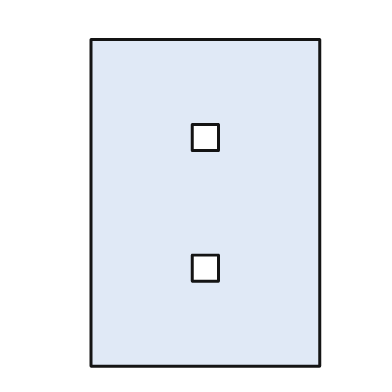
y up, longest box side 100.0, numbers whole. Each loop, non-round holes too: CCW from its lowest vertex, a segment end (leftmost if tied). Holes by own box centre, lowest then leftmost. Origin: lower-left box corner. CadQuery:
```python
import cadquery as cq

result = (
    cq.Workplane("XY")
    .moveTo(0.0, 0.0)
    .lineTo(70.0, 0.0)
    .lineTo(70.0, 100.0)
    .lineTo(0.0, 100.0)
    .close()
    .moveTo(31.0, 26.0)
    .lineTo(39.0, 26.0)
    .lineTo(39.0, 34.0)
    .lineTo(31.0, 34.0)
    .close()
    .moveTo(31.0, 66.0)
    .lineTo(39.0, 66.0)
    .lineTo(39.0, 74.0)
    .lineTo(31.0, 74.0)
    .close()
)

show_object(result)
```